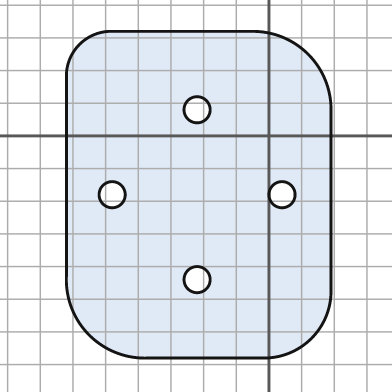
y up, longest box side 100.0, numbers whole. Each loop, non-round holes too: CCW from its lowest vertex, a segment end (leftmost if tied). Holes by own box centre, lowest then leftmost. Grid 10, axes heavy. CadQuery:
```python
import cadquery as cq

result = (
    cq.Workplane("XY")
    .moveTo(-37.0, -68.0)
    .lineTo(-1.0, -68.0)
    .threePointArc((13.0, -62.0), (19.0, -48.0))
    .lineTo(19.0, 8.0)
    .threePointArc((12.0, 25.0), (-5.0, 32.0))
    .lineTo(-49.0, 32.0)
    .threePointArc((-58.0, 28.0), (-62.0, 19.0))
    .lineTo(-62.0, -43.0)
    .threePointArc((-55.0, -61.0), (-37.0, -68.0))
    .close()
    .moveTo(-22.0, -44.0)
    .circle(4.0)
    .moveTo(-48.0, -18.0)
    .circle(4.0)
    .moveTo(4.0, -18.0)
    .circle(4.0)
    .moveTo(-22.0, 8.0)
    .circle(4.0)
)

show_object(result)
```